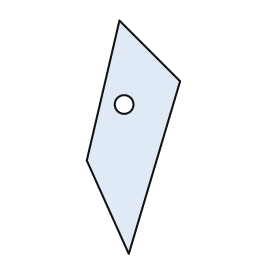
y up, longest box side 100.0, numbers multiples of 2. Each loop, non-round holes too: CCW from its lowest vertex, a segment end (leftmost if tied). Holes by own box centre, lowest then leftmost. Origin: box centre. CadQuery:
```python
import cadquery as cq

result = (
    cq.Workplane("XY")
    .moveTo(-2.0, -50.0)
    .lineTo(20.0, 24.0)
    .lineTo(-6.0, 50.0)
    .lineTo(-20.0, -10.0)
    .close()
    .moveTo(-4.0, 14.0)
    .circle(4.0)
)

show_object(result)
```